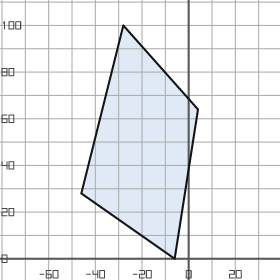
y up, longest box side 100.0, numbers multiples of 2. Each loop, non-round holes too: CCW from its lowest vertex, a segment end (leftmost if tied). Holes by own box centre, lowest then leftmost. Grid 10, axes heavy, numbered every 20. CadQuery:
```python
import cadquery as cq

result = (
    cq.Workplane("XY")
    .moveTo(-6.0, 0.0)
    .lineTo(4.0, 64.0)
    .lineTo(-28.0, 100.0)
    .lineTo(-46.0, 28.0)
    .close()
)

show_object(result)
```